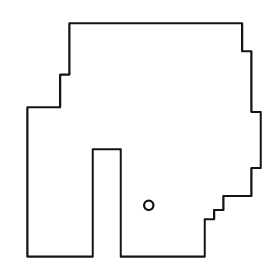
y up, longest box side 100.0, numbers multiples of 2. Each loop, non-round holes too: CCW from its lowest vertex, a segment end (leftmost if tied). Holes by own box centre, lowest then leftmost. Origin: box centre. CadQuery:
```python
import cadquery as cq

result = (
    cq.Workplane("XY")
    .moveTo(-50.0, -50.0)
    .lineTo(-22.0, -50.0)
    .lineTo(-22.0, -4.0)
    .lineTo(-10.0, -4.0)
    .lineTo(-10.0, -50.0)
    .lineTo(26.0, -50.0)
    .lineTo(26.0, -34.0)
    .lineTo(30.0, -34.0)
    .lineTo(30.0, -30.0)
    .lineTo(34.0, -30.0)
    .lineTo(34.0, -24.0)
    .lineTo(46.0, -24.0)
    .lineTo(46.0, -12.0)
    .lineTo(50.0, -12.0)
    .lineTo(50.0, 12.0)
    .lineTo(46.0, 12.0)
    .lineTo(46.0, 38.0)
    .lineTo(42.0, 38.0)
    .lineTo(42.0, 50.0)
    .lineTo(-32.0, 50.0)
    .lineTo(-32.0, 28.0)
    .lineTo(-36.0, 28.0)
    .lineTo(-36.0, 14.0)
    .lineTo(-50.0, 14.0)
    .close()
    .moveTo(2.0, -28.0)
    .circle(2.0)
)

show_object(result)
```